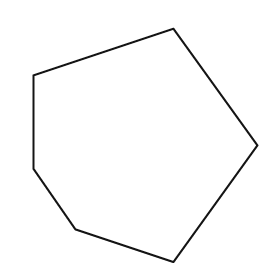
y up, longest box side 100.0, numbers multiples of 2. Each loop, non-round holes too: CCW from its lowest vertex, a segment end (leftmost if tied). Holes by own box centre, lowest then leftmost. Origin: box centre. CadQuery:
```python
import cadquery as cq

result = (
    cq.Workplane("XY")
    .moveTo(12.0, -50.0)
    .lineTo(48.0, 0.0)
    .lineTo(12.0, 50.0)
    .lineTo(-48.0, 30.0)
    .lineTo(-48.0, -10.0)
    .lineTo(-30.0, -36.0)
    .close()
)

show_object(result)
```